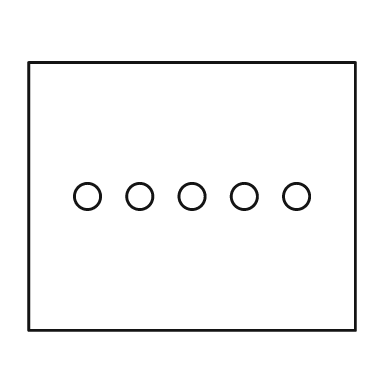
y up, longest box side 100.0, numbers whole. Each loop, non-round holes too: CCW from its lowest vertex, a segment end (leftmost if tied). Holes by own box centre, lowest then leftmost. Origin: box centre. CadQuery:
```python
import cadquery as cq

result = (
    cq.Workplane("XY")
    .moveTo(-50.0, -41.0)
    .lineTo(50.0, -41.0)
    .lineTo(50.0, 41.0)
    .lineTo(-50.0, 41.0)
    .close()
    .moveTo(-32.0, 0.0)
    .circle(4.0)
    .moveTo(-16.0, 0.0)
    .circle(4.0)
    .moveTo(0.0, 0.0)
    .circle(4.0)
    .moveTo(16.0, 0.0)
    .circle(4.0)
    .moveTo(32.0, 0.0)
    .circle(4.0)
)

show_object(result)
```